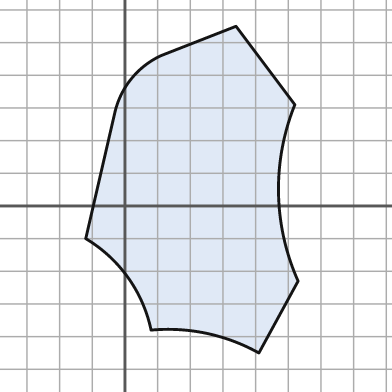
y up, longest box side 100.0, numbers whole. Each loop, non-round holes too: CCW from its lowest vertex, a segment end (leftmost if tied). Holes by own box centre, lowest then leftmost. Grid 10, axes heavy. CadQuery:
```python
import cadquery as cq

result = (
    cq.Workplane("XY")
    .moveTo(41.0, -45.0)
    .lineTo(53.0, -23.0)
    .threePointArc((47.0, 4.0), (52.0, 31.0))
    .lineTo(34.0, 55.0)
    .lineTo(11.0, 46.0)
    .threePointArc((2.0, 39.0), (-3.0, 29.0))
    .lineTo(-12.0, -10.0)
    .threePointArc((1.0, -22.0), (8.0, -38.0))
    .threePointArc((25.0, -39.0), (41.0, -45.0))
    .close()
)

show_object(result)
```